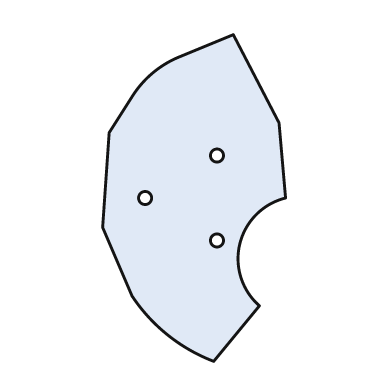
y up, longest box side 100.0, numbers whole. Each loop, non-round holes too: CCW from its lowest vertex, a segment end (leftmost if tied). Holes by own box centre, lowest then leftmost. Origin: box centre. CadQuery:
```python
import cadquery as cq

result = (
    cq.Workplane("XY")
    .moveTo(6.0, -50.0)
    .lineTo(20.0, -33.0)
    .threePointArc((14.0, -14.0), (28.0, 0.0))
    .lineTo(26.0, 23.0)
    .lineTo(12.0, 50.0)
    .lineTo(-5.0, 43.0)
    .threePointArc((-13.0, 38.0), (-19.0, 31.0))
    .lineTo(-26.0, 20.0)
    .lineTo(-28.0, -9.0)
    .lineTo(-19.0, -30.0)
    .threePointArc((-8.0, -42.0), (6.0, -50.0))
    .close()
    .moveTo(7.0, -13.0)
    .circle(2.0)
    .moveTo(-15.0, 0.0)
    .circle(2.0)
    .moveTo(7.0, 13.0)
    .circle(2.0)
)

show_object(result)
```